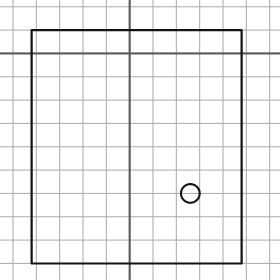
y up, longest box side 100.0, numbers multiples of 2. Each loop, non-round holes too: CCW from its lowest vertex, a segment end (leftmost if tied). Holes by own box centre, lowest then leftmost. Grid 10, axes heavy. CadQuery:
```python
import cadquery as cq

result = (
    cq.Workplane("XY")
    .moveTo(-42.0, -90.0)
    .lineTo(48.0, -90.0)
    .lineTo(48.0, 10.0)
    .lineTo(-42.0, 10.0)
    .close()
    .moveTo(26.0, -60.0)
    .circle(4.0)
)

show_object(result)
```